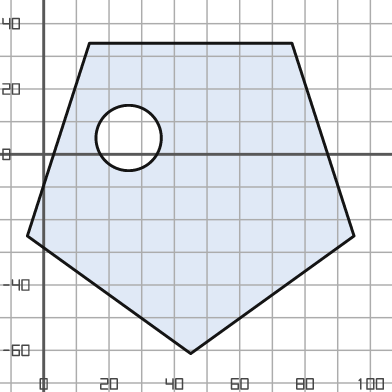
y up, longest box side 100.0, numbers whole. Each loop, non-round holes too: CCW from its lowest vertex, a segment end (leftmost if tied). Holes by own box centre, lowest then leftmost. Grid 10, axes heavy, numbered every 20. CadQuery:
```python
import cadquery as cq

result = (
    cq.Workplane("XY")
    .moveTo(45.0, -61.0)
    .lineTo(95.0, -25.0)
    .lineTo(76.0, 34.0)
    .lineTo(14.0, 34.0)
    .lineTo(-5.0, -25.0)
    .close()
    .moveTo(26.0, 5.0)
    .circle(10.0)
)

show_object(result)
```